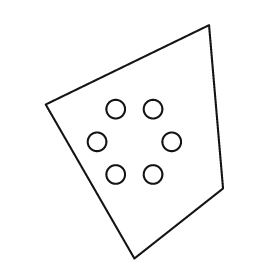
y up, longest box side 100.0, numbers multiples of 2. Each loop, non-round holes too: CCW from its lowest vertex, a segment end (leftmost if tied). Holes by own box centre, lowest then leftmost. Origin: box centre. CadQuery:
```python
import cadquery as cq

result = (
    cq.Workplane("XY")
    .moveTo(0.0, -50.0)
    .lineTo(38.0, -20.0)
    .lineTo(32.0, 50.0)
    .lineTo(-38.0, 16.0)
    .close()
    .moveTo(-8.0, -14.0)
    .circle(4.0)
    .moveTo(8.0, -14.0)
    .circle(4.0)
    .moveTo(-16.0, 0.0)
    .circle(4.0)
    .moveTo(16.0, 0.0)
    .circle(4.0)
    .moveTo(-8.0, 14.0)
    .circle(4.0)
    .moveTo(8.0, 14.0)
    .circle(4.0)
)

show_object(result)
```